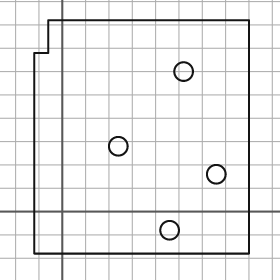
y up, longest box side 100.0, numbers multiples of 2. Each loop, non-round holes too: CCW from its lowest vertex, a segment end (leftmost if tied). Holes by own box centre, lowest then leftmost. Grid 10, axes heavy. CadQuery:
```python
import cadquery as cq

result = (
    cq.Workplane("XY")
    .moveTo(-12.0, -18.0)
    .lineTo(80.0, -18.0)
    .lineTo(80.0, 82.0)
    .lineTo(-6.0, 82.0)
    .lineTo(-6.0, 68.0)
    .lineTo(-12.0, 68.0)
    .close()
    .moveTo(46.0, -8.0)
    .circle(4.0)
    .moveTo(66.0, 16.0)
    .circle(4.0)
    .moveTo(24.0, 28.0)
    .circle(4.0)
    .moveTo(52.0, 60.0)
    .circle(4.0)
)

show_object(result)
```